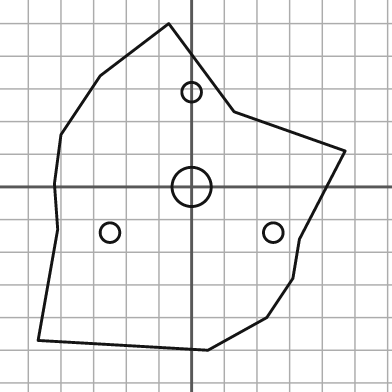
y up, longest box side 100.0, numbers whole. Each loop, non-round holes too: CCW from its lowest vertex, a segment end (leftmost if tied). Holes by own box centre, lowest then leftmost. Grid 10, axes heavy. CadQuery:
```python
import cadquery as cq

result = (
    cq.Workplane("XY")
    .moveTo(5.0, -50.0)
    .lineTo(23.0, -40.0)
    .lineTo(31.0, -28.0)
    .lineTo(33.0, -16.0)
    .lineTo(47.0, 11.0)
    .lineTo(13.0, 23.0)
    .lineTo(-7.0, 50.0)
    .lineTo(-28.0, 34.0)
    .lineTo(-40.0, 16.0)
    .lineTo(-42.0, 1.0)
    .lineTo(-41.0, -13.0)
    .lineTo(-47.0, -47.0)
    .close()
    .moveTo(-25.0, -14.0)
    .circle(3.0)
    .moveTo(25.0, -14.0)
    .circle(3.0)
    .moveTo(0.0, 0.0)
    .circle(6.0)
    .moveTo(0.0, 29.0)
    .circle(3.0)
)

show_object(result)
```